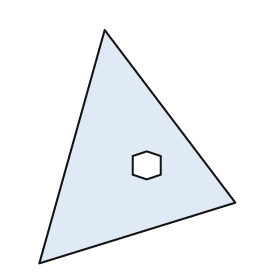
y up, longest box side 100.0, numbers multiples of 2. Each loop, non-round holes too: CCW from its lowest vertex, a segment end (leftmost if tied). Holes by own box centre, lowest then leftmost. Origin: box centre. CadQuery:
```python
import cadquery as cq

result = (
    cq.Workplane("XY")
    .moveTo(-42.0, -50.0)
    .lineTo(42.0, -24.0)
    .lineTo(-14.0, 50.0)
    .close()
    .moveTo(4.0, -14.0)
    .lineTo(10.0, -12.0)
    .lineTo(10.0, -4.0)
    .lineTo(4.0, -2.0)
    .lineTo(-2.0, -4.0)
    .lineTo(-2.0, -12.0)
    .close()
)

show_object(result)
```